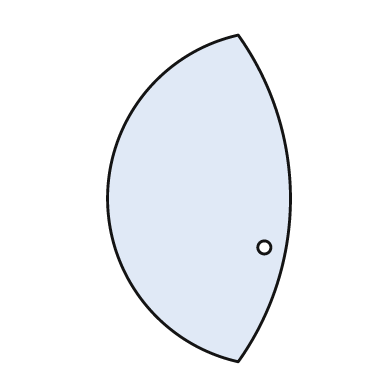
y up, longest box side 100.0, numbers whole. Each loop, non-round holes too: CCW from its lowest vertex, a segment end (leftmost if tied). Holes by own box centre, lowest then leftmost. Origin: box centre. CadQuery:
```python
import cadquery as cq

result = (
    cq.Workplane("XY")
    .moveTo(12.0, -50.0)
    .threePointArc((28.0, 0.0), (12.0, 50.0))
    .threePointArc((-28.0, 0.0), (12.0, -50.0))
    .close()
    .moveTo(20.0, -15.0)
    .circle(2.0)
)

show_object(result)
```